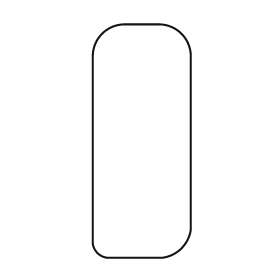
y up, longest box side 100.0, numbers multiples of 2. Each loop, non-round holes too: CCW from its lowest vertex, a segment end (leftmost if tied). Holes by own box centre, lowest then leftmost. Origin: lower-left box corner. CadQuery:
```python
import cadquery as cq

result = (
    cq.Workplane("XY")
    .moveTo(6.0, 0.0)
    .lineTo(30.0, 0.0)
    .threePointArc((38.0, 4.0), (42.0, 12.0))
    .lineTo(42.0, 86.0)
    .threePointArc((38.0, 96.0), (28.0, 100.0))
    .lineTo(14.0, 100.0)
    .threePointArc((4.0, 96.0), (0.0, 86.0))
    .lineTo(0.0, 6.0)
    .threePointArc((2.0, 2.0), (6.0, 0.0))
    .close()
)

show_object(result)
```